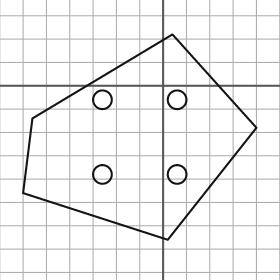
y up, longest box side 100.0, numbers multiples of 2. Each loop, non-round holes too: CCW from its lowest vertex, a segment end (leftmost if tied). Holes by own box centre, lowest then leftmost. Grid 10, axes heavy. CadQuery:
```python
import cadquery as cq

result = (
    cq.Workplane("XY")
    .moveTo(2.0, -66.0)
    .lineTo(40.0, -18.0)
    .lineTo(4.0, 22.0)
    .lineTo(-56.0, -14.0)
    .lineTo(-60.0, -46.0)
    .close()
    .moveTo(-26.0, -38.0)
    .circle(4.0)
    .moveTo(6.0, -38.0)
    .circle(4.0)
    .moveTo(-26.0, -6.0)
    .circle(4.0)
    .moveTo(6.0, -6.0)
    .circle(4.0)
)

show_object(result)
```